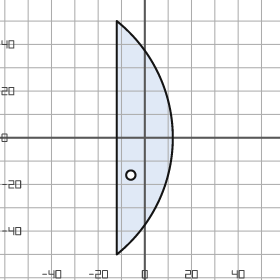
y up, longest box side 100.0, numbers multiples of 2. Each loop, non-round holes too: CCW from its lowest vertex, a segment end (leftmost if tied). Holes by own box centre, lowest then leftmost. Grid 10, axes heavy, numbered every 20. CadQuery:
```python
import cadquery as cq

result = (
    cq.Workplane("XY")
    .moveTo(-12.0, -50.0)
    .threePointArc((12.0, 0.0), (-12.0, 50.0))
    .close()
    .moveTo(-6.0, -16.0)
    .circle(2.0)
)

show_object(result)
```